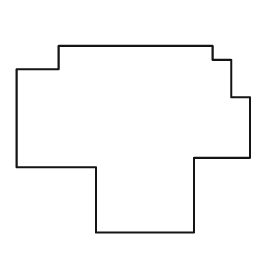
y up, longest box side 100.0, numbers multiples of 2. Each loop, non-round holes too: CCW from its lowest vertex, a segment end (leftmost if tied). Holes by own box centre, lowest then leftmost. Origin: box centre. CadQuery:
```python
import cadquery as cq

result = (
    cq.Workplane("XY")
    .moveTo(-16.0, -40.0)
    .lineTo(26.0, -40.0)
    .lineTo(26.0, -8.0)
    .lineTo(50.0, -8.0)
    .lineTo(50.0, 18.0)
    .lineTo(42.0, 18.0)
    .lineTo(42.0, 34.0)
    .lineTo(34.0, 34.0)
    .lineTo(34.0, 40.0)
    .lineTo(-32.0, 40.0)
    .lineTo(-32.0, 30.0)
    .lineTo(-50.0, 30.0)
    .lineTo(-50.0, -12.0)
    .lineTo(-16.0, -12.0)
    .close()
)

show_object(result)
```